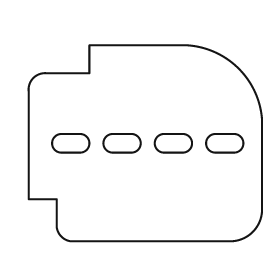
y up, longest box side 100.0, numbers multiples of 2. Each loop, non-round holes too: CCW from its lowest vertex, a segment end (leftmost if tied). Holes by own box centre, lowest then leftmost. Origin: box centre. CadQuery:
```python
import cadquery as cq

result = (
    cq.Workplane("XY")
    .moveTo(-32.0, -42.0)
    .lineTo(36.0, -42.0)
    .threePointArc((46.0, -38.0), (50.0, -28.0))
    .lineTo(50.0, 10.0)
    .threePointArc((40.0, 32.0), (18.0, 42.0))
    .lineTo(-24.0, 42.0)
    .lineTo(-24.0, 30.0)
    .lineTo(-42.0, 30.0)
    .threePointArc((-48.0, 28.0), (-50.0, 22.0))
    .lineTo(-50.0, -24.0)
    .lineTo(-38.0, -24.0)
    .lineTo(-38.0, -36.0)
    .threePointArc((-36.0, -40.0), (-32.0, -42.0))
    .close()
    .moveTo(-36.0, -4.0)
    .lineTo(-28.0, -4.0)
    .threePointArc((-24.0, 0.0), (-28.0, 4.0))
    .lineTo(-36.0, 4.0)
    .threePointArc((-40.0, 0.0), (-36.0, -4.0))
    .close()
    .moveTo(-14.0, -4.0)
    .lineTo(-6.0, -4.0)
    .threePointArc((-2.0, 0.0), (-6.0, 4.0))
    .lineTo(-14.0, 4.0)
    .threePointArc((-18.0, 0.0), (-14.0, -4.0))
    .close()
    .moveTo(8.0, -4.0)
    .lineTo(16.0, -4.0)
    .threePointArc((20.0, 0.0), (16.0, 4.0))
    .lineTo(8.0, 4.0)
    .threePointArc((4.0, 0.0), (8.0, -4.0))
    .close()
    .moveTo(30.0, -4.0)
    .lineTo(38.0, -4.0)
    .threePointArc((42.0, 0.0), (38.0, 4.0))
    .lineTo(30.0, 4.0)
    .threePointArc((26.0, 0.0), (30.0, -4.0))
    .close()
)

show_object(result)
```